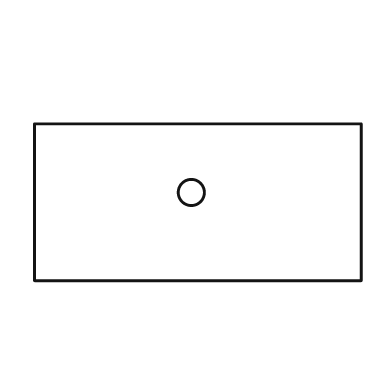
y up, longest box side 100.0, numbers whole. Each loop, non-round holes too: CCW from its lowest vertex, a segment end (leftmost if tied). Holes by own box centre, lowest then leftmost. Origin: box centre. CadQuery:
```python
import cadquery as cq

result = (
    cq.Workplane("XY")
    .moveTo(-50.0, -24.0)
    .lineTo(50.0, -24.0)
    .lineTo(50.0, 24.0)
    .lineTo(-50.0, 24.0)
    .close()
    .moveTo(-2.0, 3.0)
    .circle(4.0)
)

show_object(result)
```